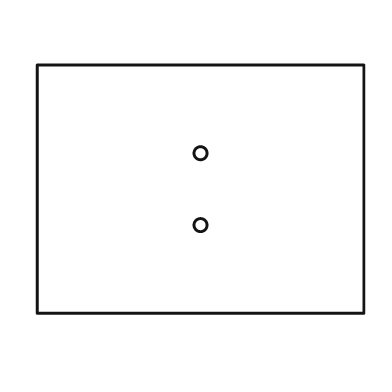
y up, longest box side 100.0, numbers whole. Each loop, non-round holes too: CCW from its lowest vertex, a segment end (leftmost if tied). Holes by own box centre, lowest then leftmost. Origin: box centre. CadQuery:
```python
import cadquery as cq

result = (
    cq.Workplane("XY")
    .moveTo(-50.0, -38.0)
    .lineTo(50.0, -38.0)
    .lineTo(50.0, 38.0)
    .lineTo(-50.0, 38.0)
    .close()
    .moveTo(0.0, -11.0)
    .circle(2.0)
    .moveTo(0.0, 11.0)
    .circle(2.0)
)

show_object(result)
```